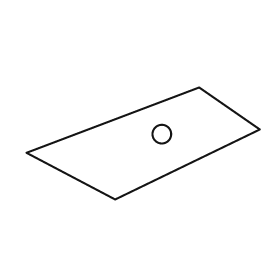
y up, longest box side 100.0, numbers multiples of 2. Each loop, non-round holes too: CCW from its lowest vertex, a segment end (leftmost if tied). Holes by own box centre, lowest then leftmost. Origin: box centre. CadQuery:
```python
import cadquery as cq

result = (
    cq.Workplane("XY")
    .moveTo(-12.0, -24.0)
    .lineTo(50.0, 6.0)
    .lineTo(24.0, 24.0)
    .lineTo(-50.0, -4.0)
    .close()
    .moveTo(8.0, 4.0)
    .circle(4.0)
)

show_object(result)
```